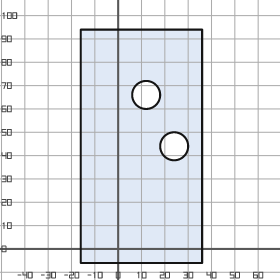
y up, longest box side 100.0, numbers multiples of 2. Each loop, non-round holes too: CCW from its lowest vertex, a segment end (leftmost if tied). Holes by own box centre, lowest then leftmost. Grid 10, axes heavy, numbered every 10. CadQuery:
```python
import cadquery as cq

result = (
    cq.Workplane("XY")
    .moveTo(-16.0, -6.0)
    .lineTo(36.0, -6.0)
    .lineTo(36.0, 94.0)
    .lineTo(-16.0, 94.0)
    .close()
    .moveTo(24.0, 44.0)
    .circle(6.0)
    .moveTo(12.0, 66.0)
    .circle(6.0)
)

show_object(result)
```